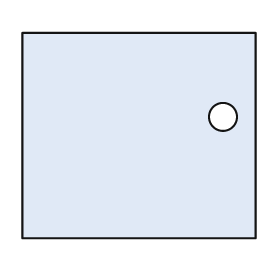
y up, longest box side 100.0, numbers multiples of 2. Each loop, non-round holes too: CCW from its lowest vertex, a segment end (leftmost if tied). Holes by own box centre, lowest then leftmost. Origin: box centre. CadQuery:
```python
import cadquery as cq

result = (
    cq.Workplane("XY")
    .moveTo(-50.0, -44.0)
    .lineTo(50.0, -44.0)
    .lineTo(50.0, 44.0)
    .lineTo(-50.0, 44.0)
    .close()
    .moveTo(36.0, 8.0)
    .circle(6.0)
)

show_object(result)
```